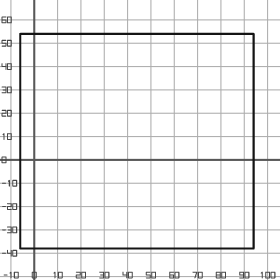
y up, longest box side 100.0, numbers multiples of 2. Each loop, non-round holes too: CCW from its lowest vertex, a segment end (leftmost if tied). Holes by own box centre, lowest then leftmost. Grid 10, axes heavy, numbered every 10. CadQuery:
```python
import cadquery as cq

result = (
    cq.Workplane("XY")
    .moveTo(-6.0, -38.0)
    .lineTo(94.0, -38.0)
    .lineTo(94.0, 54.0)
    .lineTo(-6.0, 54.0)
    .close()
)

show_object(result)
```